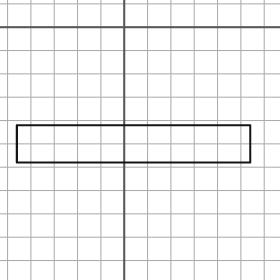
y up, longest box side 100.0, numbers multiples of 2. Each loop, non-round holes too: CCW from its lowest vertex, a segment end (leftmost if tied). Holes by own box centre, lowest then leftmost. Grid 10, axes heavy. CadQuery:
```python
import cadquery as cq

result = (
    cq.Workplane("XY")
    .moveTo(-46.0, -58.0)
    .lineTo(54.0, -58.0)
    .lineTo(54.0, -42.0)
    .lineTo(-46.0, -42.0)
    .close()
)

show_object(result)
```